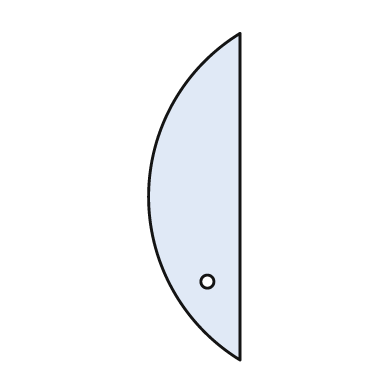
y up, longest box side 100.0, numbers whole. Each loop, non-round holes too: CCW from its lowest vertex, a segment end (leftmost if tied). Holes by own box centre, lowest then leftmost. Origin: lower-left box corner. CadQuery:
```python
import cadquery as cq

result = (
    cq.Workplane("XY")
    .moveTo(28.0, 0.0)
    .lineTo(28.0, 100.0)
    .threePointArc((0.0, 50.0), (28.0, 0.0))
    .close()
    .moveTo(18.0, 24.0)
    .circle(2.0)
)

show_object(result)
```